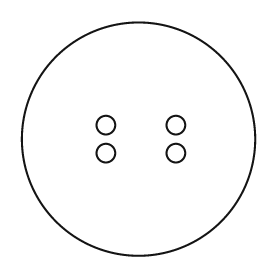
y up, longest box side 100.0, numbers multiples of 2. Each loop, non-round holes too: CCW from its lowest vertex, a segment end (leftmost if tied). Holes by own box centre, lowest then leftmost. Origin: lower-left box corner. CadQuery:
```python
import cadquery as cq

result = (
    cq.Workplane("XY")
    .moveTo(50.0, 50.0)
    .circle(50.0)
    .moveTo(36.0, 44.0)
    .circle(4.0)
    .moveTo(66.0, 44.0)
    .circle(4.0)
    .moveTo(36.0, 56.0)
    .circle(4.0)
    .moveTo(66.0, 56.0)
    .circle(4.0)
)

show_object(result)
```